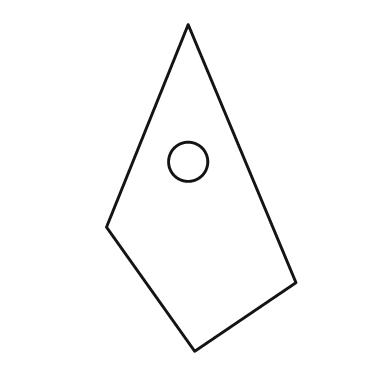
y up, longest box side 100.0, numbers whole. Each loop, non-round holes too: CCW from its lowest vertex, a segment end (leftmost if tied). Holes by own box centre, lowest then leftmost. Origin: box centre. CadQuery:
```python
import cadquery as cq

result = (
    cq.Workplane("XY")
    .moveTo(-2.0, -50.0)
    .lineTo(29.0, -29.0)
    .lineTo(-4.0, 50.0)
    .lineTo(-29.0, -12.0)
    .close()
    .moveTo(-4.0, 8.0)
    .circle(6.0)
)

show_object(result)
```